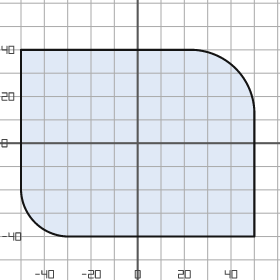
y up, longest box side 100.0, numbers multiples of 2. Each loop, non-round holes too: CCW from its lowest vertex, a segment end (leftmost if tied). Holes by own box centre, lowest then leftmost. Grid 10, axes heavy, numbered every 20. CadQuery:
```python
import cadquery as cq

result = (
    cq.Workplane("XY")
    .moveTo(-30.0, -40.0)
    .lineTo(50.0, -40.0)
    .lineTo(50.0, 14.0)
    .threePointArc((42.0, 32.0), (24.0, 40.0))
    .lineTo(-50.0, 40.0)
    .lineTo(-50.0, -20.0)
    .threePointArc((-44.0, -34.0), (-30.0, -40.0))
    .close()
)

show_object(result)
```